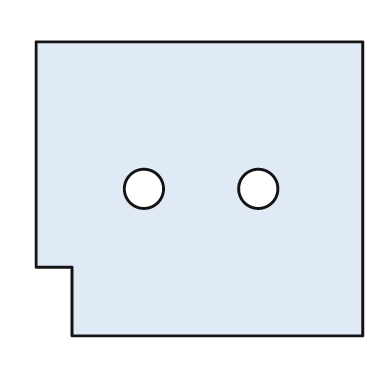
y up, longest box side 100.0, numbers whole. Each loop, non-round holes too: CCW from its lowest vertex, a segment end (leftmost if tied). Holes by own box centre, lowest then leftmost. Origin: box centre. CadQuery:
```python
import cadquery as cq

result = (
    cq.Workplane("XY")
    .moveTo(-39.0, -45.0)
    .lineTo(50.0, -45.0)
    .lineTo(50.0, 45.0)
    .lineTo(-50.0, 45.0)
    .lineTo(-50.0, -24.0)
    .lineTo(-39.0, -24.0)
    .close()
    .moveTo(-17.0, 0.0)
    .circle(6.0)
    .moveTo(18.0, 0.0)
    .circle(6.0)
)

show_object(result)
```